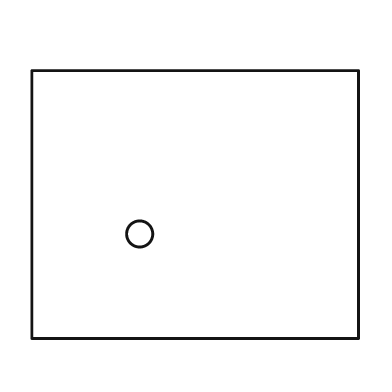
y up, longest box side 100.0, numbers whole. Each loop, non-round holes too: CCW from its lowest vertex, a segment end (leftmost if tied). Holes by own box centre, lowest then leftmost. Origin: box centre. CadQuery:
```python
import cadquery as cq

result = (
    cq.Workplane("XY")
    .moveTo(-50.0, -41.0)
    .lineTo(50.0, -41.0)
    .lineTo(50.0, 41.0)
    .lineTo(-50.0, 41.0)
    .close()
    .moveTo(-17.0, -9.0)
    .circle(4.0)
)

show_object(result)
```